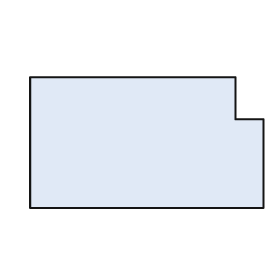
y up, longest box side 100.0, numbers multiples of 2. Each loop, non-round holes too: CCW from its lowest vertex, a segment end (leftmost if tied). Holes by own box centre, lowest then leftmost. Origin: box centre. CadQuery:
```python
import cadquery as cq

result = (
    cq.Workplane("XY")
    .moveTo(-50.0, -28.0)
    .lineTo(50.0, -28.0)
    .lineTo(50.0, 10.0)
    .lineTo(38.0, 10.0)
    .lineTo(38.0, 28.0)
    .lineTo(-50.0, 28.0)
    .close()
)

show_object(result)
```